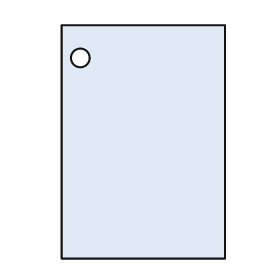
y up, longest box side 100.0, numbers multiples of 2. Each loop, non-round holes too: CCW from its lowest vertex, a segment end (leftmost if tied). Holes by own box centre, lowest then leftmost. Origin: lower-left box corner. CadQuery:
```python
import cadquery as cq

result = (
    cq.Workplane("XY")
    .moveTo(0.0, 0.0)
    .lineTo(70.0, 0.0)
    .lineTo(70.0, 100.0)
    .lineTo(0.0, 100.0)
    .close()
    .moveTo(8.0, 86.0)
    .circle(4.0)
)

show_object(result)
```